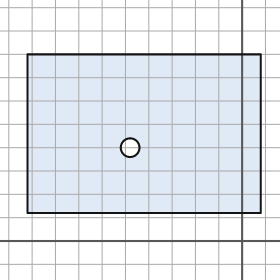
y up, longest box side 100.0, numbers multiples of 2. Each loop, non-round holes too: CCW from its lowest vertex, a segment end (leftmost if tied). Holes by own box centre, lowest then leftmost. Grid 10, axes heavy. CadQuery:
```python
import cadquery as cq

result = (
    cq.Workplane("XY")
    .moveTo(-92.0, 12.0)
    .lineTo(8.0, 12.0)
    .lineTo(8.0, 80.0)
    .lineTo(-92.0, 80.0)
    .close()
    .moveTo(-48.0, 40.0)
    .circle(4.0)
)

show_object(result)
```